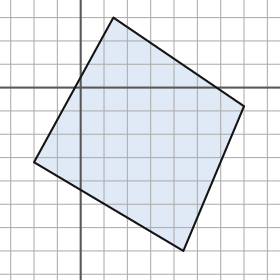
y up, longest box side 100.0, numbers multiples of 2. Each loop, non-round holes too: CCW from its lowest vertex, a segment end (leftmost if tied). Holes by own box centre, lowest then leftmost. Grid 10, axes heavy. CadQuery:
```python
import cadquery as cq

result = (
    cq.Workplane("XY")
    .moveTo(44.0, -70.0)
    .lineTo(70.0, -8.0)
    .lineTo(14.0, 30.0)
    .lineTo(-20.0, -32.0)
    .close()
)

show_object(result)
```